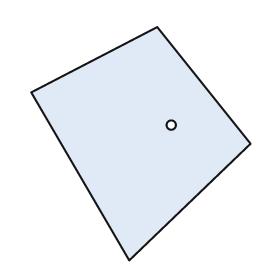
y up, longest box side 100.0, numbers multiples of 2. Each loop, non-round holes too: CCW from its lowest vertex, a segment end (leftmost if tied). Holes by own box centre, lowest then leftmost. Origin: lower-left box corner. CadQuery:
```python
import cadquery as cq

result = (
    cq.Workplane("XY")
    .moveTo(42.0, 0.0)
    .lineTo(94.0, 50.0)
    .lineTo(54.0, 100.0)
    .lineTo(0.0, 72.0)
    .close()
    .moveTo(60.0, 58.0)
    .circle(2.0)
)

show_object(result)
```